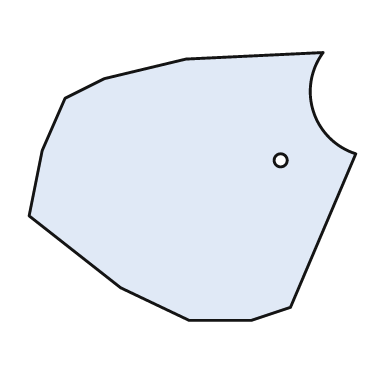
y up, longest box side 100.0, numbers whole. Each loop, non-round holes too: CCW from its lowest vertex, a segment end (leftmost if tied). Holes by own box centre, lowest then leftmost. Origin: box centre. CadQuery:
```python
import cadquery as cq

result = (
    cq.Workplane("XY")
    .moveTo(-1.0, -41.0)
    .lineTo(18.0, -41.0)
    .lineTo(30.0, -37.0)
    .lineTo(50.0, 10.0)
    .threePointArc((37.0, 23.0), (40.0, 41.0))
    .lineTo(-2.0, 39.0)
    .lineTo(-27.0, 33.0)
    .lineTo(-39.0, 27.0)
    .lineTo(-46.0, 11.0)
    .lineTo(-50.0, -9.0)
    .lineTo(-22.0, -31.0)
    .close()
    .moveTo(27.0, 8.0)
    .circle(2.0)
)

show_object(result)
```